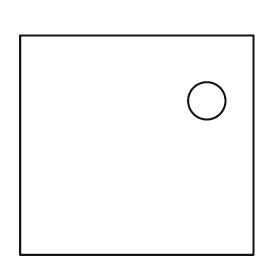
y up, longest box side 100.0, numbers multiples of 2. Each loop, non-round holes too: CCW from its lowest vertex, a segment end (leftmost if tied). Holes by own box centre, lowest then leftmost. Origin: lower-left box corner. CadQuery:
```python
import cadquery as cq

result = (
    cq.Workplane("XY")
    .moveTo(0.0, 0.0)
    .lineTo(100.0, 0.0)
    .lineTo(100.0, 94.0)
    .lineTo(0.0, 94.0)
    .close()
    .moveTo(80.0, 66.0)
    .circle(8.0)
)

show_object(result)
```